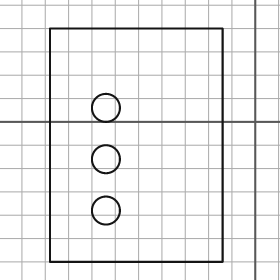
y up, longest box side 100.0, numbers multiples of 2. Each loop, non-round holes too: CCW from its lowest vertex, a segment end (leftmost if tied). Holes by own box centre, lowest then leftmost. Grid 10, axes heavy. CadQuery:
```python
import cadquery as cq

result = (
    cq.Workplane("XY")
    .moveTo(-88.0, -60.0)
    .lineTo(-14.0, -60.0)
    .lineTo(-14.0, 40.0)
    .lineTo(-88.0, 40.0)
    .close()
    .moveTo(-64.0, -38.0)
    .circle(6.0)
    .moveTo(-64.0, -16.0)
    .circle(6.0)
    .moveTo(-64.0, 6.0)
    .circle(6.0)
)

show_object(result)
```